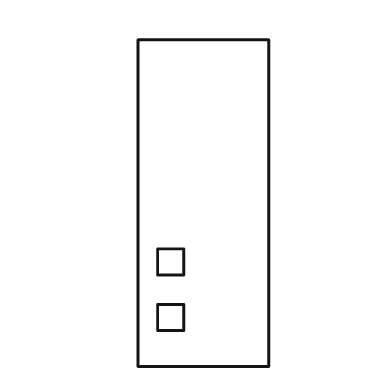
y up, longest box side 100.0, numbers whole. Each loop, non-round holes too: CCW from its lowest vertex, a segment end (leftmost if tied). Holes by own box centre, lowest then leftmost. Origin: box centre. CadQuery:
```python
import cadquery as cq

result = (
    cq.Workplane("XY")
    .moveTo(-20.0, -50.0)
    .lineTo(20.0, -50.0)
    .lineTo(20.0, 50.0)
    .lineTo(-20.0, 50.0)
    .close()
    .moveTo(-14.0, -39.0)
    .lineTo(-6.0, -39.0)
    .lineTo(-6.0, -31.0)
    .lineTo(-14.0, -31.0)
    .close()
    .moveTo(-14.0, -22.0)
    .lineTo(-6.0, -22.0)
    .lineTo(-6.0, -14.0)
    .lineTo(-14.0, -14.0)
    .close()
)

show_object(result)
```